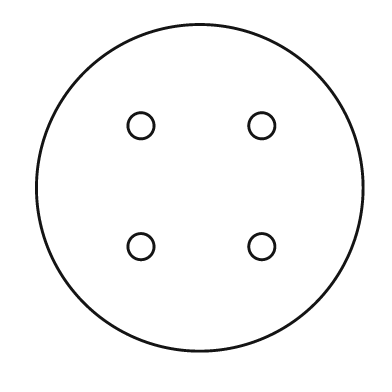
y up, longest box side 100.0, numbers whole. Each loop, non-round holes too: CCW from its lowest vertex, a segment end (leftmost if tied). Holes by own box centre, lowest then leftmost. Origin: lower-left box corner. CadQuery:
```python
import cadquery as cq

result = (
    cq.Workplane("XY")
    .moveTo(50.0, 50.0)
    .circle(50.0)
    .moveTo(32.0, 32.0)
    .circle(4.0)
    .moveTo(69.0, 32.0)
    .circle(4.0)
    .moveTo(32.0, 69.0)
    .circle(4.0)
    .moveTo(69.0, 69.0)
    .circle(4.0)
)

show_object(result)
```